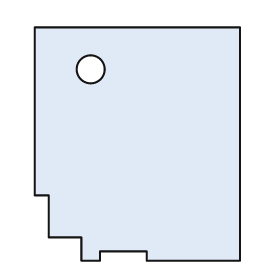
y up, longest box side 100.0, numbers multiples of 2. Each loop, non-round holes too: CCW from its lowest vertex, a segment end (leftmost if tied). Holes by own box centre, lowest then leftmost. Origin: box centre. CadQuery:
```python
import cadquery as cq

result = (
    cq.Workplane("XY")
    .moveTo(-24.0, -50.0)
    .lineTo(-16.0, -50.0)
    .lineTo(-16.0, -46.0)
    .lineTo(4.0, -46.0)
    .lineTo(4.0, -50.0)
    .lineTo(44.0, -50.0)
    .lineTo(44.0, 50.0)
    .lineTo(-44.0, 50.0)
    .lineTo(-44.0, -22.0)
    .lineTo(-38.0, -22.0)
    .lineTo(-38.0, -40.0)
    .lineTo(-24.0, -40.0)
    .close()
    .moveTo(-20.0, 32.0)
    .circle(6.0)
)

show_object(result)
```